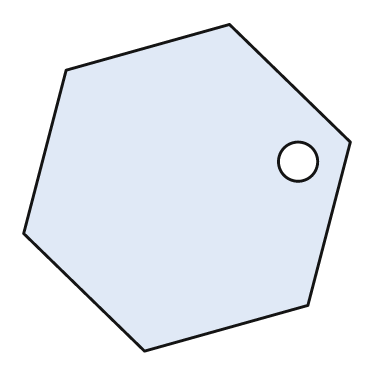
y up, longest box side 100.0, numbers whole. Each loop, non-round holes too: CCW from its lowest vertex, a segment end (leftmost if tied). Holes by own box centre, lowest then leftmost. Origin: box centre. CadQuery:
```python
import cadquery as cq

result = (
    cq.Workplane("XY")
    .moveTo(-13.0, -50.0)
    .lineTo(37.0, -36.0)
    .lineTo(50.0, 14.0)
    .lineTo(13.0, 50.0)
    .lineTo(-37.0, 36.0)
    .lineTo(-50.0, -14.0)
    .close()
    .moveTo(34.0, 8.0)
    .circle(6.0)
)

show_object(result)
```